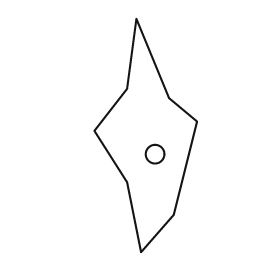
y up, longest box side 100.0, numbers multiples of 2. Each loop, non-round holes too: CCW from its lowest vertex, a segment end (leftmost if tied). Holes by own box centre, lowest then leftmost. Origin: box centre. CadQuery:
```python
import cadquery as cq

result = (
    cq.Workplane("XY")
    .moveTo(-2.0, -50.0)
    .lineTo(12.0, -34.0)
    .lineTo(22.0, 6.0)
    .lineTo(10.0, 16.0)
    .lineTo(-4.0, 50.0)
    .lineTo(-8.0, 20.0)
    .lineTo(-22.0, 2.0)
    .lineTo(-8.0, -20.0)
    .close()
    .moveTo(4.0, -8.0)
    .circle(4.0)
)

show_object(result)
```